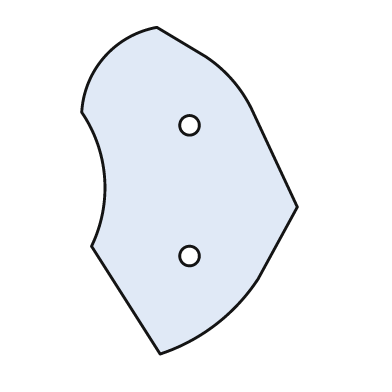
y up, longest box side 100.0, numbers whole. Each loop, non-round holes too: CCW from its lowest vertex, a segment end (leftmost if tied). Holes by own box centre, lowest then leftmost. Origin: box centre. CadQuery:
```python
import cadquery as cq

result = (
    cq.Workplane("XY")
    .moveTo(-9.0, -50.0)
    .threePointArc((8.0, -41.0), (21.0, -27.0))
    .lineTo(33.0, -5.0)
    .lineTo(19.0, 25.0)
    .threePointArc((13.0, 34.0), (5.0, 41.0))
    .lineTo(-10.0, 50.0)
    .threePointArc((-26.0, 41.0), (-33.0, 24.0))
    .threePointArc((-26.0, 4.0), (-30.0, -17.0))
    .close()
    .moveTo(0.0, -20.0)
    .circle(3.0)
    .moveTo(0.0, 20.0)
    .circle(3.0)
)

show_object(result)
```